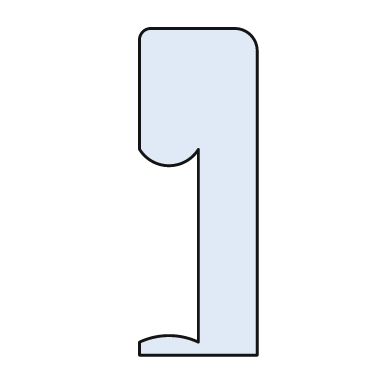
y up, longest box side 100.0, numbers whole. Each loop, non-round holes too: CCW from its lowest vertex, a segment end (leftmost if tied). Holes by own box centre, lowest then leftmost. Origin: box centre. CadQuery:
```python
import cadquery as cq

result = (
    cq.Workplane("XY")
    .moveTo(-18.0, -50.0)
    .lineTo(18.0, -50.0)
    .lineTo(18.0, 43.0)
    .threePointArc((16.0, 48.0), (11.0, 50.0))
    .lineTo(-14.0, 50.0)
    .threePointArc((-17.0, 49.0), (-18.0, 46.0))
    .lineTo(-18.0, 13.0)
    .threePointArc((-9.0, 8.0), (0.0, 13.0))
    .lineTo(0.0, -46.0)
    .threePointArc((-9.0, -44.0), (-18.0, -46.0))
    .close()
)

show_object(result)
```